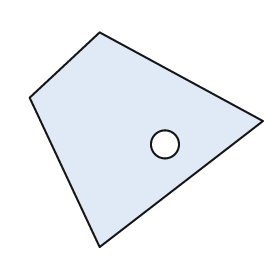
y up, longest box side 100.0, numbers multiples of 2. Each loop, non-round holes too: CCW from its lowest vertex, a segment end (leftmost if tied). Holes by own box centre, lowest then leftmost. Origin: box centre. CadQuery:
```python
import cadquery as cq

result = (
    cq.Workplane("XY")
    .moveTo(-20.0, -46.0)
    .lineTo(50.0, 8.0)
    .lineTo(-20.0, 46.0)
    .lineTo(-50.0, 18.0)
    .close()
    .moveTo(8.0, -2.0)
    .circle(6.0)
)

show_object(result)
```